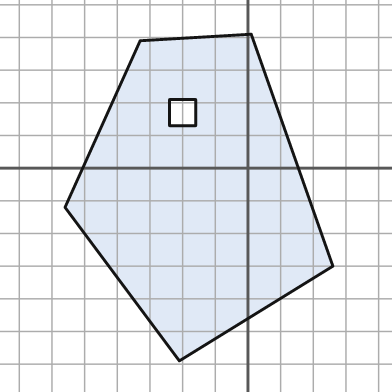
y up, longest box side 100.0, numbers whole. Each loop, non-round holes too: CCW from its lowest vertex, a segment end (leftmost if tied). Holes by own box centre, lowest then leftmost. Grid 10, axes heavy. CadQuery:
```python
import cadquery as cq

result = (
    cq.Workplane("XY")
    .moveTo(-21.0, -59.0)
    .lineTo(26.0, -30.0)
    .lineTo(1.0, 41.0)
    .lineTo(-33.0, 39.0)
    .lineTo(-56.0, -12.0)
    .close()
    .moveTo(-24.0, 13.0)
    .lineTo(-16.0, 13.0)
    .lineTo(-16.0, 21.0)
    .lineTo(-24.0, 21.0)
    .close()
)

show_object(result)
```